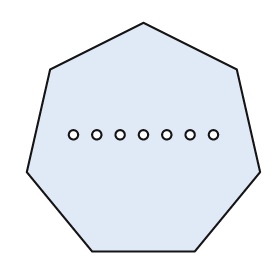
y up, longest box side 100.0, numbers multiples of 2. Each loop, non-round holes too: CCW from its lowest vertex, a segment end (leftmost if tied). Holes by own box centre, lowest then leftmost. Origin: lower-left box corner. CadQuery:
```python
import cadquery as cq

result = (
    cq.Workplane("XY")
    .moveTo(28.0, 0.0)
    .lineTo(72.0, 0.0)
    .lineTo(100.0, 34.0)
    .lineTo(90.0, 78.0)
    .lineTo(50.0, 98.0)
    .lineTo(10.0, 78.0)
    .lineTo(0.0, 34.0)
    .close()
    .moveTo(20.0, 50.0)
    .circle(2.0)
    .moveTo(30.0, 50.0)
    .circle(2.0)
    .moveTo(40.0, 50.0)
    .circle(2.0)
    .moveTo(50.0, 50.0)
    .circle(2.0)
    .moveTo(60.0, 50.0)
    .circle(2.0)
    .moveTo(70.0, 50.0)
    .circle(2.0)
    .moveTo(80.0, 50.0)
    .circle(2.0)
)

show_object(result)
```